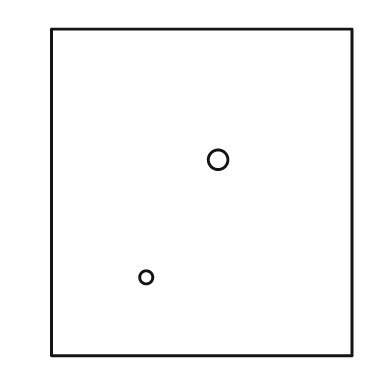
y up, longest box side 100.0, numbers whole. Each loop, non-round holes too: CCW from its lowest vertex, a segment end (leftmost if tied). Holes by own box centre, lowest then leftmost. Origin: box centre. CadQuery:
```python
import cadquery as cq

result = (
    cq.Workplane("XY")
    .moveTo(-46.0, -50.0)
    .lineTo(46.0, -50.0)
    .lineTo(46.0, 50.0)
    .lineTo(-46.0, 50.0)
    .close()
    .moveTo(-17.0, -26.0)
    .circle(2.0)
    .moveTo(5.0, 10.0)
    .circle(3.0)
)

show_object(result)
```